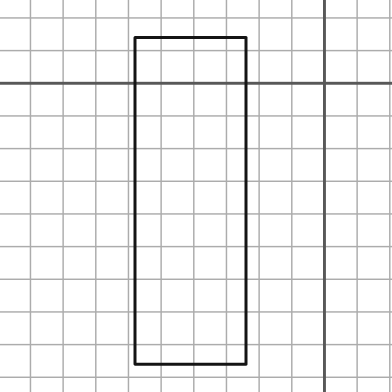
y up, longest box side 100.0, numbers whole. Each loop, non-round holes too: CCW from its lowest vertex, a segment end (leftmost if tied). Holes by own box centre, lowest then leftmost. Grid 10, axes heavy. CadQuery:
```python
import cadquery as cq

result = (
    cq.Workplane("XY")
    .moveTo(-58.0, -86.0)
    .lineTo(-24.0, -86.0)
    .lineTo(-24.0, 14.0)
    .lineTo(-58.0, 14.0)
    .close()
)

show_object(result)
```